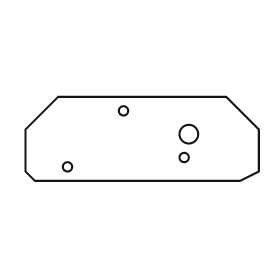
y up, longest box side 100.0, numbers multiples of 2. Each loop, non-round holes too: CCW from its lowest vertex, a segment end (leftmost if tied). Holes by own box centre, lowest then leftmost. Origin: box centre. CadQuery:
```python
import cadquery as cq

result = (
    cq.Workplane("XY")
    .moveTo(-46.0, -18.0)
    .lineTo(42.0, -18.0)
    .lineTo(50.0, -14.0)
    .lineTo(50.0, 4.0)
    .lineTo(36.0, 18.0)
    .lineTo(-36.0, 18.0)
    .lineTo(-50.0, 4.0)
    .lineTo(-50.0, -14.0)
    .close()
    .moveTo(-32.0, -12.0)
    .circle(2.0)
    .moveTo(18.0, -8.0)
    .circle(2.0)
    .moveTo(20.0, 2.0)
    .circle(4.0)
    .moveTo(-8.0, 12.0)
    .circle(2.0)
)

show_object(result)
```